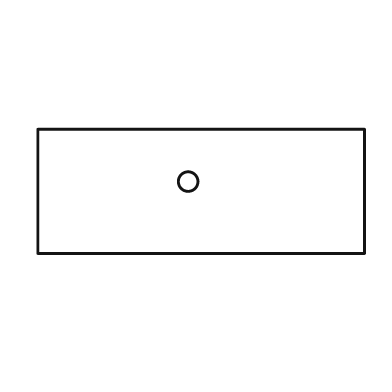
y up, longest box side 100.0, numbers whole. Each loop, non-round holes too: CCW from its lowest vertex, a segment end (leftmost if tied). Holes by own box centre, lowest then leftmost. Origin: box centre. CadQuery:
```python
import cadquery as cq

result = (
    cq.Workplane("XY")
    .moveTo(-50.0, -19.0)
    .lineTo(50.0, -19.0)
    .lineTo(50.0, 19.0)
    .lineTo(-50.0, 19.0)
    .close()
    .moveTo(-4.0, 3.0)
    .circle(3.0)
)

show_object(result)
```